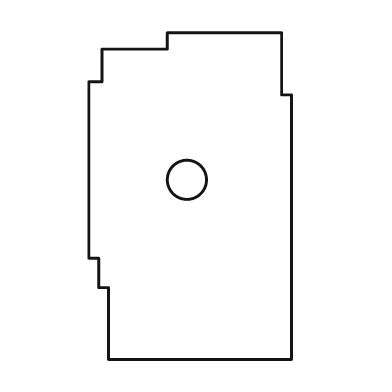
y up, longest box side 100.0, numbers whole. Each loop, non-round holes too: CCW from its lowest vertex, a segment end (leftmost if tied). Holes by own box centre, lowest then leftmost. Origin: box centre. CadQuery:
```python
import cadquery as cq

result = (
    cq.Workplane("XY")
    .moveTo(-25.0, -50.0)
    .lineTo(31.0, -50.0)
    .lineTo(31.0, 31.0)
    .lineTo(28.0, 31.0)
    .lineTo(28.0, 50.0)
    .lineTo(-7.0, 50.0)
    .lineTo(-7.0, 45.0)
    .lineTo(-27.0, 45.0)
    .lineTo(-27.0, 35.0)
    .lineTo(-31.0, 35.0)
    .lineTo(-31.0, -19.0)
    .lineTo(-28.0, -19.0)
    .lineTo(-28.0, -28.0)
    .lineTo(-25.0, -28.0)
    .close()
    .moveTo(-1.0, 5.0)
    .circle(6.0)
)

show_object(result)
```